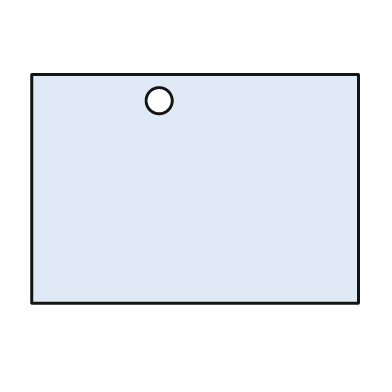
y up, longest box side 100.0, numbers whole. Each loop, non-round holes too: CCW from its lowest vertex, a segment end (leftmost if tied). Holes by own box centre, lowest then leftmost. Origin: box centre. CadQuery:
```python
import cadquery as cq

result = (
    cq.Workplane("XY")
    .moveTo(-50.0, -35.0)
    .lineTo(50.0, -35.0)
    .lineTo(50.0, 35.0)
    .lineTo(-50.0, 35.0)
    .close()
    .moveTo(-11.0, 27.0)
    .circle(4.0)
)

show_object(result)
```